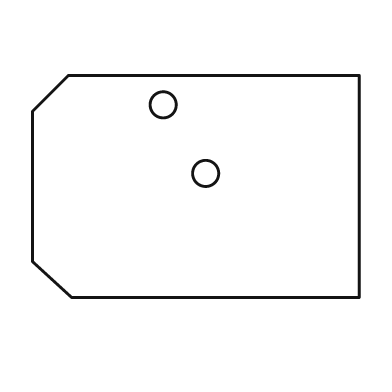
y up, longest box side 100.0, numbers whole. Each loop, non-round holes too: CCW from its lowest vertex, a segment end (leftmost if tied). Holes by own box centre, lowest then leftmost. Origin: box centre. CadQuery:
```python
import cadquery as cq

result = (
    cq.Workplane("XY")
    .moveTo(-38.0, -34.0)
    .lineTo(50.0, -34.0)
    .lineTo(50.0, 34.0)
    .lineTo(-39.0, 34.0)
    .lineTo(-50.0, 23.0)
    .lineTo(-50.0, -23.0)
    .close()
    .moveTo(3.0, 4.0)
    .circle(4.0)
    .moveTo(-10.0, 25.0)
    .circle(4.0)
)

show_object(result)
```